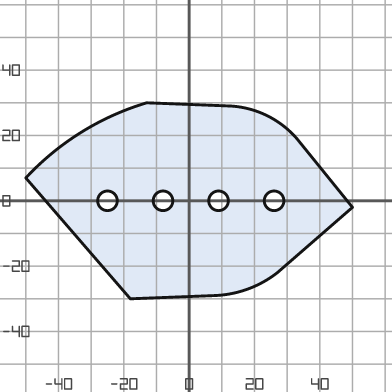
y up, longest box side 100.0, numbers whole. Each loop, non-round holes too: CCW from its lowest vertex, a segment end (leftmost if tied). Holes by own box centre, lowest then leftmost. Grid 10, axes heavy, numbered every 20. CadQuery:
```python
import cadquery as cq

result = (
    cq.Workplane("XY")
    .moveTo(-18.0, -30.0)
    .lineTo(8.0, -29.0)
    .threePointArc((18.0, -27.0), (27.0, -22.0))
    .lineTo(50.0, -2.0)
    .lineTo(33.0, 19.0)
    .threePointArc((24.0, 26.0), (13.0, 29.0))
    .lineTo(-13.0, 30.0)
    .threePointArc((-33.0, 21.0), (-50.0, 7.0))
    .close()
    .moveTo(-25.0, 0.0)
    .circle(3.0)
    .moveTo(-8.0, 0.0)
    .circle(3.0)
    .moveTo(9.0, 0.0)
    .circle(3.0)
    .moveTo(26.0, 0.0)
    .circle(3.0)
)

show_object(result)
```